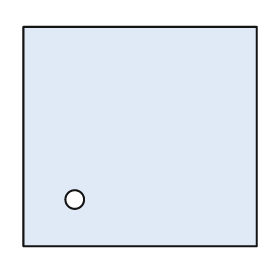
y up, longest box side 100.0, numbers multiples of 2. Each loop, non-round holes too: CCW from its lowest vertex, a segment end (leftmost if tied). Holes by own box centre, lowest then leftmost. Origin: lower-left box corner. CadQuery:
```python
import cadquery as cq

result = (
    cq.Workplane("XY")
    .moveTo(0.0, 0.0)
    .lineTo(100.0, 0.0)
    .lineTo(100.0, 94.0)
    .lineTo(0.0, 94.0)
    .close()
    .moveTo(22.0, 20.0)
    .circle(4.0)
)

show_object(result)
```